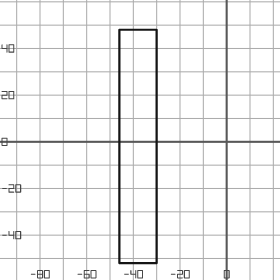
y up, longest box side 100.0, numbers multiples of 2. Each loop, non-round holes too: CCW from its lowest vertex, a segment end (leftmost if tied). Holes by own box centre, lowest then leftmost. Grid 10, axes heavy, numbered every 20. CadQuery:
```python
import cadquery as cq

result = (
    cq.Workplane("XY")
    .moveTo(-46.0, -52.0)
    .lineTo(-30.0, -52.0)
    .lineTo(-30.0, 48.0)
    .lineTo(-46.0, 48.0)
    .close()
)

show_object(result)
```